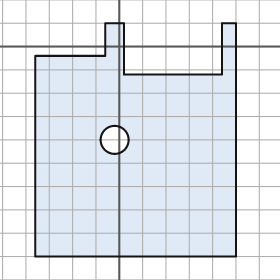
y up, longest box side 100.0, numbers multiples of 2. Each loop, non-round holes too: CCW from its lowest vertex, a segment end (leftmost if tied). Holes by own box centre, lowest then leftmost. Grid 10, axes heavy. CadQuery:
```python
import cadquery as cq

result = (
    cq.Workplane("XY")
    .moveTo(-36.0, -90.0)
    .lineTo(50.0, -90.0)
    .lineTo(50.0, 10.0)
    .lineTo(44.0, 10.0)
    .lineTo(44.0, -12.0)
    .lineTo(2.0, -12.0)
    .lineTo(2.0, 10.0)
    .lineTo(-6.0, 10.0)
    .lineTo(-6.0, -4.0)
    .lineTo(-36.0, -4.0)
    .close()
    .moveTo(-2.0, -40.0)
    .circle(6.0)
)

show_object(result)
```